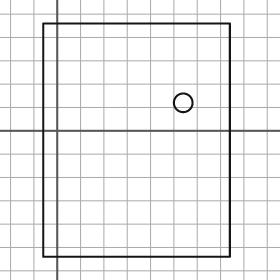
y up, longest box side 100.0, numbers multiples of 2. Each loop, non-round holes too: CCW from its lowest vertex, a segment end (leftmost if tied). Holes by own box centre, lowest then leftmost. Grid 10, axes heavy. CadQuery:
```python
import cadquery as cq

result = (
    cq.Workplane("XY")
    .moveTo(-6.0, -54.0)
    .lineTo(74.0, -54.0)
    .lineTo(74.0, 46.0)
    .lineTo(-6.0, 46.0)
    .close()
    .moveTo(54.0, 12.0)
    .circle(4.0)
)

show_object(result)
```